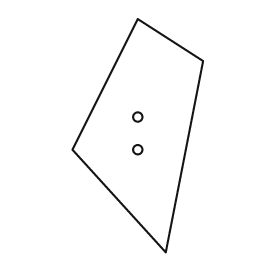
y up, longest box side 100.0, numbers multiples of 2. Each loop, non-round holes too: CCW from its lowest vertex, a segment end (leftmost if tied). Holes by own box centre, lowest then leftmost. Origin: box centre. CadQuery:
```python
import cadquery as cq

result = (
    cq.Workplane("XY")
    .moveTo(12.0, -50.0)
    .lineTo(28.0, 32.0)
    .lineTo(0.0, 50.0)
    .lineTo(-28.0, -6.0)
    .close()
    .moveTo(0.0, -6.0)
    .circle(2.0)
    .moveTo(0.0, 8.0)
    .circle(2.0)
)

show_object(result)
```